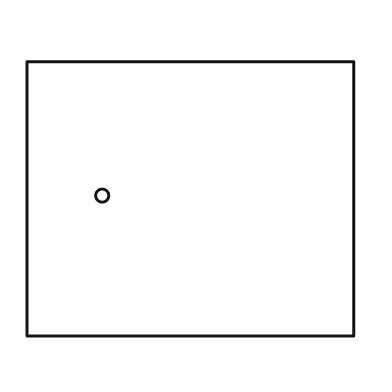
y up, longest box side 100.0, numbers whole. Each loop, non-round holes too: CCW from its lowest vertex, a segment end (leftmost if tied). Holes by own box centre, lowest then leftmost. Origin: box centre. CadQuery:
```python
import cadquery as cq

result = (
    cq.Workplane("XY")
    .moveTo(-50.0, -42.0)
    .lineTo(50.0, -42.0)
    .lineTo(50.0, 42.0)
    .lineTo(-50.0, 42.0)
    .close()
    .moveTo(-27.0, 1.0)
    .circle(2.0)
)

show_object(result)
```